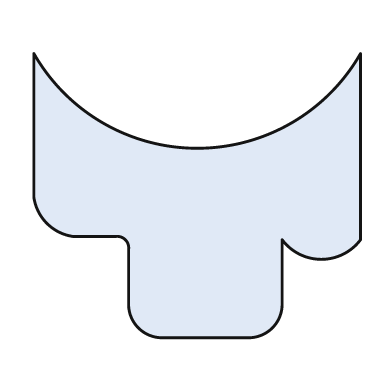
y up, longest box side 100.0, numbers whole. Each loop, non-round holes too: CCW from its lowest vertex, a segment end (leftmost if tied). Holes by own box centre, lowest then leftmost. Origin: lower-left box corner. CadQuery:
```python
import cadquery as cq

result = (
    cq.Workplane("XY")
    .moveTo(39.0, 0.0)
    .lineTo(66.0, 0.0)
    .threePointArc((73.0, 3.0), (76.0, 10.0))
    .lineTo(76.0, 30.0)
    .threePointArc((88.0, 24.0), (100.0, 30.0))
    .lineTo(100.0, 87.0)
    .threePointArc((50.0, 58.0), (0.0, 87.0))
    .lineTo(0.0, 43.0)
    .threePointArc((4.0, 35.0), (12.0, 31.0))
    .lineTo(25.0, 31.0)
    .threePointArc((28.0, 30.0), (29.0, 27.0))
    .lineTo(29.0, 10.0)
    .threePointArc((32.0, 3.0), (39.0, 0.0))
    .close()
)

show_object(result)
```